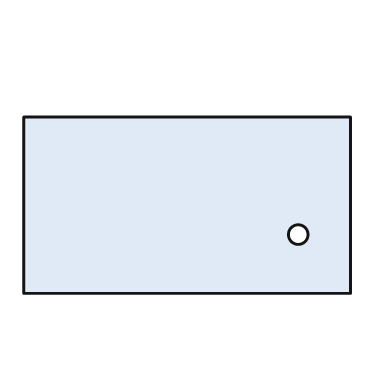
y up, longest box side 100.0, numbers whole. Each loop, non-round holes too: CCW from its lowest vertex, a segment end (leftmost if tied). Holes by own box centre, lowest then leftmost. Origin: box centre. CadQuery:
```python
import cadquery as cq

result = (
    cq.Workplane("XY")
    .moveTo(-50.0, -27.0)
    .lineTo(50.0, -27.0)
    .lineTo(50.0, 27.0)
    .lineTo(-50.0, 27.0)
    .close()
    .moveTo(34.0, -9.0)
    .circle(3.0)
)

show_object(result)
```